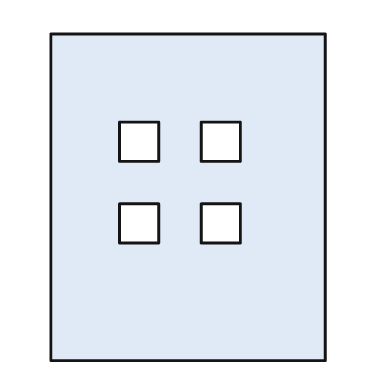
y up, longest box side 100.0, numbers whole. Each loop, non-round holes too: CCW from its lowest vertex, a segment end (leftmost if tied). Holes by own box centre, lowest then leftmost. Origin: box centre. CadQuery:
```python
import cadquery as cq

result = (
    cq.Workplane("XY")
    .moveTo(-42.0, -50.0)
    .lineTo(42.0, -50.0)
    .lineTo(42.0, 50.0)
    .lineTo(-42.0, 50.0)
    .close()
    .moveTo(-21.0, -14.0)
    .lineTo(-9.0, -14.0)
    .lineTo(-9.0, -2.0)
    .lineTo(-21.0, -2.0)
    .close()
    .moveTo(4.0, -14.0)
    .lineTo(16.0, -14.0)
    .lineTo(16.0, -2.0)
    .lineTo(4.0, -2.0)
    .close()
    .moveTo(-21.0, 11.0)
    .lineTo(-9.0, 11.0)
    .lineTo(-9.0, 23.0)
    .lineTo(-21.0, 23.0)
    .close()
    .moveTo(4.0, 11.0)
    .lineTo(16.0, 11.0)
    .lineTo(16.0, 23.0)
    .lineTo(4.0, 23.0)
    .close()
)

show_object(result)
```